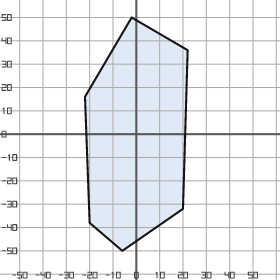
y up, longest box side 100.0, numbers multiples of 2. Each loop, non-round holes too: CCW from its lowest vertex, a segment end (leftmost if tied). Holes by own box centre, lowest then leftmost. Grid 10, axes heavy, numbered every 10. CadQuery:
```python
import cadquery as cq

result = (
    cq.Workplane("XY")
    .moveTo(-6.0, -50.0)
    .lineTo(20.0, -32.0)
    .lineTo(22.0, 36.0)
    .lineTo(-2.0, 50.0)
    .lineTo(-22.0, 16.0)
    .lineTo(-20.0, -38.0)
    .close()
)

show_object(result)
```